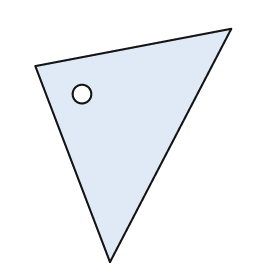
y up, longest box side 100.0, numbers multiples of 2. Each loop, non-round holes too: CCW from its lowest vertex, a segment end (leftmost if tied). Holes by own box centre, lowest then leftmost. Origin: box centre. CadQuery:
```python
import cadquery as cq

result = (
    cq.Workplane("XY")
    .moveTo(-10.0, -50.0)
    .lineTo(42.0, 50.0)
    .lineTo(-42.0, 34.0)
    .close()
    .moveTo(-22.0, 22.0)
    .circle(4.0)
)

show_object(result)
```